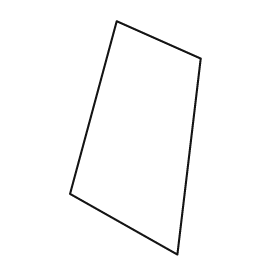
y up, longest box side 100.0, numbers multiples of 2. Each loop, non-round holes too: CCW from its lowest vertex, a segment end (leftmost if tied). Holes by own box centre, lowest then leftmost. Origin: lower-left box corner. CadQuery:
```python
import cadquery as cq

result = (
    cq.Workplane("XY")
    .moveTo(46.0, 0.0)
    .lineTo(56.0, 84.0)
    .lineTo(20.0, 100.0)
    .lineTo(0.0, 26.0)
    .close()
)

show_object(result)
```